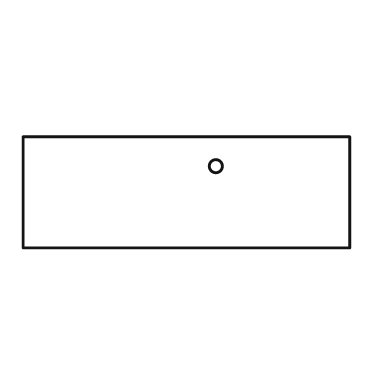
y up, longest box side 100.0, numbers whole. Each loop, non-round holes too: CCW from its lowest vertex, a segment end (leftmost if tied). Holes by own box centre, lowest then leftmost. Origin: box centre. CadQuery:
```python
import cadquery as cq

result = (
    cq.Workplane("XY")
    .moveTo(-50.0, -17.0)
    .lineTo(50.0, -17.0)
    .lineTo(50.0, 17.0)
    .lineTo(-50.0, 17.0)
    .close()
    .moveTo(9.0, 8.0)
    .circle(2.0)
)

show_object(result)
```